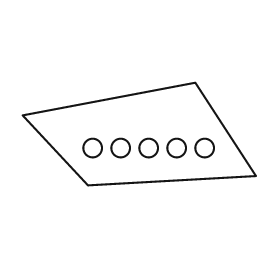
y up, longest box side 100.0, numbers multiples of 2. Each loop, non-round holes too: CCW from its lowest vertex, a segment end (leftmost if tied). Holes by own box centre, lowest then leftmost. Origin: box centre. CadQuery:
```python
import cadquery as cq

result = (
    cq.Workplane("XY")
    .moveTo(-22.0, -22.0)
    .lineTo(50.0, -18.0)
    .lineTo(24.0, 22.0)
    .lineTo(-50.0, 8.0)
    .close()
    .moveTo(-20.0, -6.0)
    .circle(4.0)
    .moveTo(-8.0, -6.0)
    .circle(4.0)
    .moveTo(4.0, -6.0)
    .circle(4.0)
    .moveTo(16.0, -6.0)
    .circle(4.0)
    .moveTo(28.0, -6.0)
    .circle(4.0)
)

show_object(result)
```